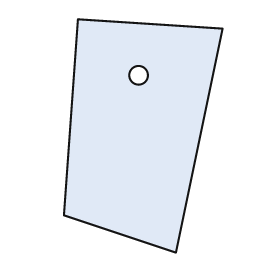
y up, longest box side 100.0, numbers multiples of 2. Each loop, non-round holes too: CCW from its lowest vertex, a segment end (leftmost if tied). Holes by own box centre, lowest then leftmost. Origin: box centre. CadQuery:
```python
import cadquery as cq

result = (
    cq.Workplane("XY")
    .moveTo(14.0, -50.0)
    .lineTo(34.0, 46.0)
    .lineTo(-28.0, 50.0)
    .lineTo(-34.0, -34.0)
    .close()
    .moveTo(-2.0, 26.0)
    .circle(4.0)
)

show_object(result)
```